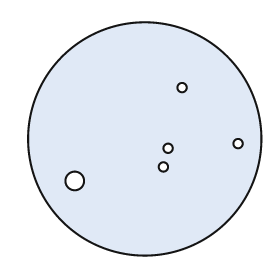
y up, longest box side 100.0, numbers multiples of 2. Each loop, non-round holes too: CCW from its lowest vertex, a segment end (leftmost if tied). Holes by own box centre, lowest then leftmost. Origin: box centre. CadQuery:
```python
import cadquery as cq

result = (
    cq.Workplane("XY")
    .moveTo(0.0, 0.0)
    .circle(50.0)
    .moveTo(-30.0, -18.0)
    .circle(4.0)
    .moveTo(8.0, -12.0)
    .circle(2.0)
    .moveTo(10.0, -4.0)
    .circle(2.0)
    .moveTo(40.0, -2.0)
    .circle(2.0)
    .moveTo(16.0, 22.0)
    .circle(2.0)
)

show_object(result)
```